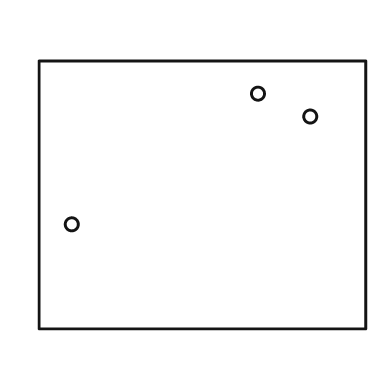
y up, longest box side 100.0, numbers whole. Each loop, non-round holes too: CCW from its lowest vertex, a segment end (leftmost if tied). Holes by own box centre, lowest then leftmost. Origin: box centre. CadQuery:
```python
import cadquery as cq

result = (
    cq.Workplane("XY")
    .moveTo(-50.0, -41.0)
    .lineTo(50.0, -41.0)
    .lineTo(50.0, 41.0)
    .lineTo(-50.0, 41.0)
    .close()
    .moveTo(-40.0, -9.0)
    .circle(2.0)
    .moveTo(33.0, 24.0)
    .circle(2.0)
    .moveTo(17.0, 31.0)
    .circle(2.0)
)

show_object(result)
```